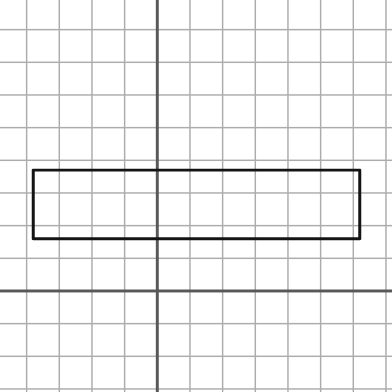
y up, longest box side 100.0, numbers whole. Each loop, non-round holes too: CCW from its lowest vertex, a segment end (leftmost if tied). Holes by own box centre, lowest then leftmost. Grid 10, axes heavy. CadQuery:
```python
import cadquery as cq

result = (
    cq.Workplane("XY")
    .moveTo(-38.0, 16.0)
    .lineTo(62.0, 16.0)
    .lineTo(62.0, 37.0)
    .lineTo(-38.0, 37.0)
    .close()
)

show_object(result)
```